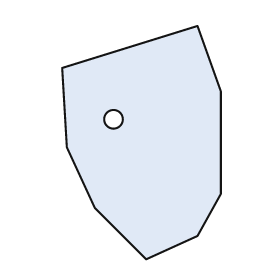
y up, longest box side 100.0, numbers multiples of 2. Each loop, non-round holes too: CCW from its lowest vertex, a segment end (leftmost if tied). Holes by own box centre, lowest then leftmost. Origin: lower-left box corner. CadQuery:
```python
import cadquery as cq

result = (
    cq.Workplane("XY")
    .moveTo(36.0, 0.0)
    .lineTo(58.0, 10.0)
    .lineTo(68.0, 28.0)
    .lineTo(68.0, 72.0)
    .lineTo(58.0, 100.0)
    .lineTo(0.0, 82.0)
    .lineTo(2.0, 48.0)
    .lineTo(14.0, 22.0)
    .close()
    .moveTo(22.0, 60.0)
    .circle(4.0)
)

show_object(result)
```